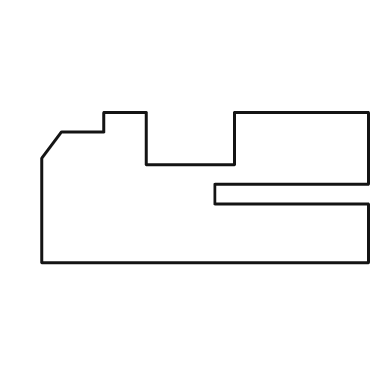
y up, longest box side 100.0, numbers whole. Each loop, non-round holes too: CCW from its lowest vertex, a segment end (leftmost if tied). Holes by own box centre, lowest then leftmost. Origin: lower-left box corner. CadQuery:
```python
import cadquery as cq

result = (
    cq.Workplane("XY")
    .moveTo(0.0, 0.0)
    .lineTo(100.0, 0.0)
    .lineTo(100.0, 18.0)
    .lineTo(53.0, 18.0)
    .lineTo(53.0, 24.0)
    .lineTo(100.0, 24.0)
    .lineTo(100.0, 46.0)
    .lineTo(59.0, 46.0)
    .lineTo(59.0, 30.0)
    .lineTo(32.0, 30.0)
    .lineTo(32.0, 46.0)
    .lineTo(19.0, 46.0)
    .lineTo(19.0, 40.0)
    .lineTo(6.0, 40.0)
    .lineTo(0.0, 32.0)
    .close()
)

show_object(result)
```